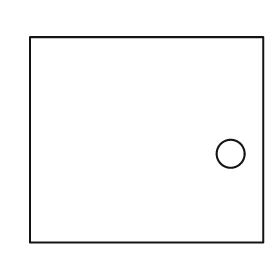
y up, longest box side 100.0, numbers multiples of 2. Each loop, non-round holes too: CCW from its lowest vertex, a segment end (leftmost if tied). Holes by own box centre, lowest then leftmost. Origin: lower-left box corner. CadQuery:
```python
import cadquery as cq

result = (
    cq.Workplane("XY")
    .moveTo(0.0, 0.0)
    .lineTo(100.0, 0.0)
    .lineTo(100.0, 88.0)
    .lineTo(0.0, 88.0)
    .close()
    .moveTo(86.0, 38.0)
    .circle(6.0)
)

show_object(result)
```